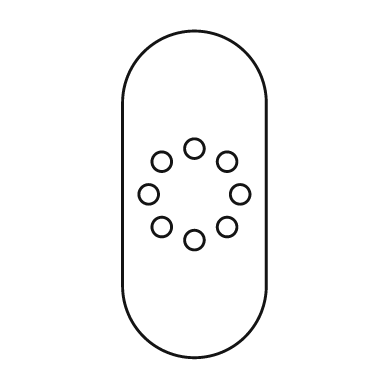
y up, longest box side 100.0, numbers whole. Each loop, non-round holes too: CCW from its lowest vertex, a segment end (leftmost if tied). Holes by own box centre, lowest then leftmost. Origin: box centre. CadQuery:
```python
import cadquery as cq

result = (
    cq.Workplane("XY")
    .moveTo(-22.0, -28.0)
    .threePointArc((0.0, -50.0), (22.0, -28.0))
    .lineTo(22.0, 28.0)
    .threePointArc((0.0, 50.0), (-22.0, 28.0))
    .close()
    .moveTo(0.0, -14.0)
    .circle(3.0)
    .moveTo(-10.0, -10.0)
    .circle(3.0)
    .moveTo(10.0, -10.0)
    .circle(3.0)
    .moveTo(-14.0, 0.0)
    .circle(3.0)
    .moveTo(14.0, 0.0)
    .circle(3.0)
    .moveTo(-10.0, 10.0)
    .circle(3.0)
    .moveTo(10.0, 10.0)
    .circle(3.0)
    .moveTo(0.0, 14.0)
    .circle(3.0)
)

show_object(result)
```